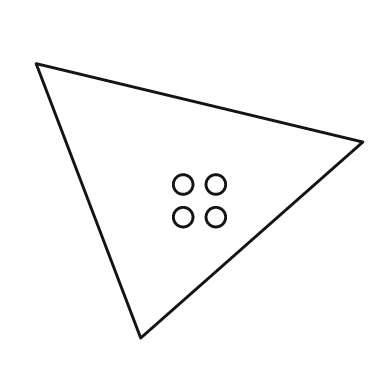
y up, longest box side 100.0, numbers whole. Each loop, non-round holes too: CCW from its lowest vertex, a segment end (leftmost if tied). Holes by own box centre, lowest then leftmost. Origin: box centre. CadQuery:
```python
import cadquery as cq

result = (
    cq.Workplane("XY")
    .moveTo(-18.0, -42.0)
    .lineTo(50.0, 18.0)
    .lineTo(-50.0, 42.0)
    .close()
    .moveTo(-5.0, -5.0)
    .circle(3.0)
    .moveTo(5.0, -5.0)
    .circle(3.0)
    .moveTo(-5.0, 5.0)
    .circle(3.0)
    .moveTo(5.0, 5.0)
    .circle(3.0)
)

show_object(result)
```